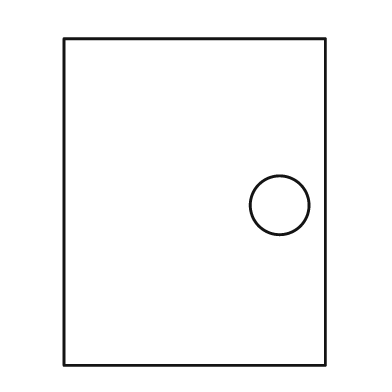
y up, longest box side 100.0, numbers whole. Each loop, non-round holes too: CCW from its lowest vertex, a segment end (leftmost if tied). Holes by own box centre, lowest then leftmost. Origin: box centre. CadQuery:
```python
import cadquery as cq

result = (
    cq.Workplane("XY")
    .moveTo(-40.0, -50.0)
    .lineTo(40.0, -50.0)
    .lineTo(40.0, 50.0)
    .lineTo(-40.0, 50.0)
    .close()
    .moveTo(26.0, -1.0)
    .circle(9.0)
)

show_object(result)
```